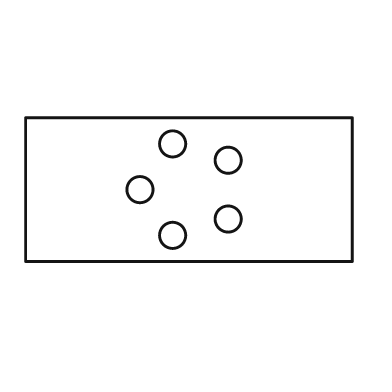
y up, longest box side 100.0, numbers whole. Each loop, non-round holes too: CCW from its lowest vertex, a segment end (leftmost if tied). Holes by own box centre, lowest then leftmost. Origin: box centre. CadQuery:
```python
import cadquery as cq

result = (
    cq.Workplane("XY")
    .moveTo(-50.0, -22.0)
    .lineTo(50.0, -22.0)
    .lineTo(50.0, 22.0)
    .lineTo(-50.0, 22.0)
    .close()
    .moveTo(-5.0, -14.0)
    .circle(4.0)
    .moveTo(12.0, -9.0)
    .circle(4.0)
    .moveTo(-15.0, 0.0)
    .circle(4.0)
    .moveTo(12.0, 9.0)
    .circle(4.0)
    .moveTo(-5.0, 14.0)
    .circle(4.0)
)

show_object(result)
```